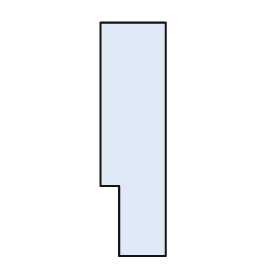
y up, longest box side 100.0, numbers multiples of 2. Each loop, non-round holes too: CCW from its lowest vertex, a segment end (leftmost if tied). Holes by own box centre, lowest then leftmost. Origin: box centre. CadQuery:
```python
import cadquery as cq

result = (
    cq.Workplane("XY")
    .moveTo(-6.0, -50.0)
    .lineTo(14.0, -50.0)
    .lineTo(14.0, 50.0)
    .lineTo(-14.0, 50.0)
    .lineTo(-14.0, -20.0)
    .lineTo(-6.0, -20.0)
    .close()
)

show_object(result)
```